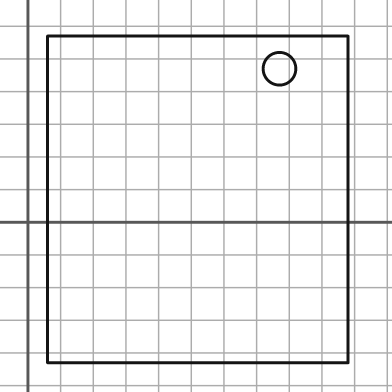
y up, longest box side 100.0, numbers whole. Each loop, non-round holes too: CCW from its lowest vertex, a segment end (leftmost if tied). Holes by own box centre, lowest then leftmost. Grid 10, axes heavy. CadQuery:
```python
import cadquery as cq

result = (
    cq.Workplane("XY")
    .moveTo(6.0, -43.0)
    .lineTo(98.0, -43.0)
    .lineTo(98.0, 57.0)
    .lineTo(6.0, 57.0)
    .close()
    .moveTo(77.0, 47.0)
    .circle(5.0)
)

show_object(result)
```